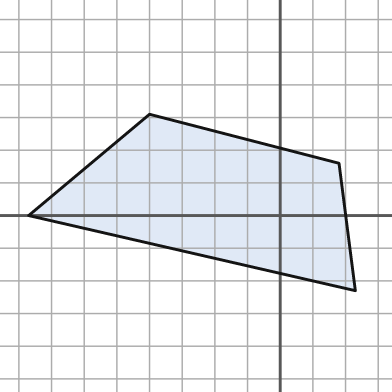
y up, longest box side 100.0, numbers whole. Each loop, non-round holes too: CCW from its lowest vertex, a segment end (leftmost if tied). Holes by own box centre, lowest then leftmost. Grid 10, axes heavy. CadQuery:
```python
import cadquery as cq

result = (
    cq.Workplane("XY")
    .moveTo(23.0, -23.0)
    .lineTo(18.0, 16.0)
    .lineTo(-40.0, 31.0)
    .lineTo(-77.0, 0.0)
    .close()
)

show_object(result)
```